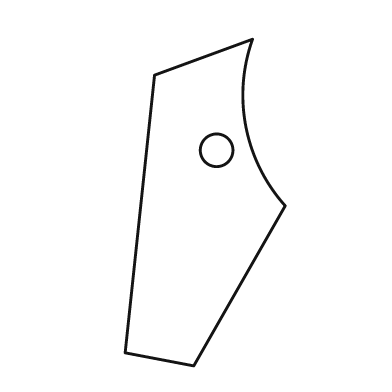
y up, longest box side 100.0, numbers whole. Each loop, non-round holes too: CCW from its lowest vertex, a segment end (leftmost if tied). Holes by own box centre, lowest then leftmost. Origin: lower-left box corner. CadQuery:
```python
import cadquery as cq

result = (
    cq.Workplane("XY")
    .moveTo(21.0, 0.0)
    .lineTo(49.0, 49.0)
    .threePointArc((37.0, 73.0), (39.0, 100.0))
    .lineTo(9.0, 89.0)
    .lineTo(0.0, 4.0)
    .close()
    .moveTo(28.0, 66.0)
    .circle(5.0)
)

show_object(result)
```